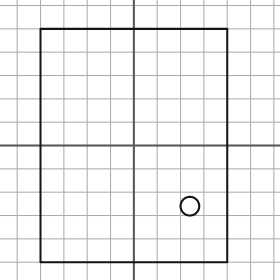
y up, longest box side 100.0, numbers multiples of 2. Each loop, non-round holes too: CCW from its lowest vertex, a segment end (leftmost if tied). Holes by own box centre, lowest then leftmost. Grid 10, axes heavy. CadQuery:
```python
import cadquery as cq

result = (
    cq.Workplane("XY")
    .moveTo(-40.0, -50.0)
    .lineTo(40.0, -50.0)
    .lineTo(40.0, 50.0)
    .lineTo(-40.0, 50.0)
    .close()
    .moveTo(24.0, -26.0)
    .circle(4.0)
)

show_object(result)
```